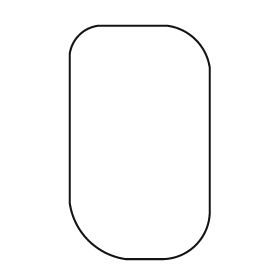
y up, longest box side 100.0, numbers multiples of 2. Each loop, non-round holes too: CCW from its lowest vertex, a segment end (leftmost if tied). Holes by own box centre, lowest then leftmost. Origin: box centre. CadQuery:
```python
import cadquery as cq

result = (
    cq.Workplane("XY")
    .moveTo(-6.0, -50.0)
    .lineTo(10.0, -50.0)
    .threePointArc((24.0, -44.0), (30.0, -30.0))
    .lineTo(30.0, 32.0)
    .threePointArc((24.0, 44.0), (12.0, 50.0))
    .lineTo(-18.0, 50.0)
    .threePointArc((-26.0, 46.0), (-30.0, 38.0))
    .lineTo(-30.0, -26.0)
    .threePointArc((-22.0, -42.0), (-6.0, -50.0))
    .close()
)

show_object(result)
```